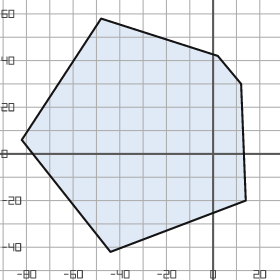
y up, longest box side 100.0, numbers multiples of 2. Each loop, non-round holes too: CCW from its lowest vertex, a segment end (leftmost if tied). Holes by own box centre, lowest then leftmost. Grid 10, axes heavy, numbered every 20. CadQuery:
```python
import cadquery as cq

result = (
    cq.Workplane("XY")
    .moveTo(-44.0, -42.0)
    .lineTo(14.0, -20.0)
    .lineTo(12.0, 30.0)
    .lineTo(2.0, 42.0)
    .lineTo(-48.0, 58.0)
    .lineTo(-82.0, 6.0)
    .close()
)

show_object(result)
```